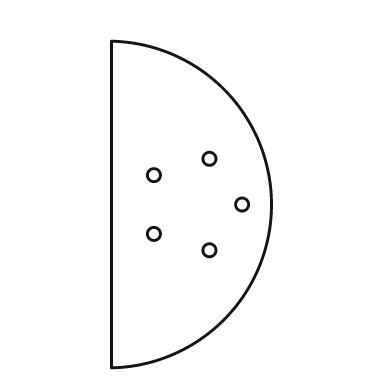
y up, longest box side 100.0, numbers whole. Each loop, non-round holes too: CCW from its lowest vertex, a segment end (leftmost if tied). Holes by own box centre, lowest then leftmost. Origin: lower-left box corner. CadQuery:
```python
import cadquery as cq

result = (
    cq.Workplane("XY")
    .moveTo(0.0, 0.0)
    .threePointArc((49.0, 50.0), (0.0, 100.0))
    .close()
    .moveTo(30.0, 36.0)
    .circle(2.0)
    .moveTo(13.0, 41.0)
    .circle(2.0)
    .moveTo(40.0, 50.0)
    .circle(2.0)
    .moveTo(13.0, 59.0)
    .circle(2.0)
    .moveTo(30.0, 64.0)
    .circle(2.0)
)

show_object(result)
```